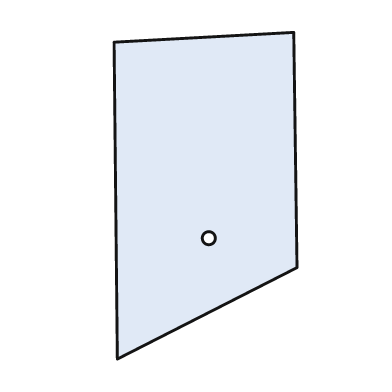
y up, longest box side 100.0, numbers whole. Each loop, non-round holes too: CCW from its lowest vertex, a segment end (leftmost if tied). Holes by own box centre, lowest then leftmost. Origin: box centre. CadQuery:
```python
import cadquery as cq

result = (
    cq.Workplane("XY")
    .moveTo(-27.0, -50.0)
    .lineTo(28.0, -22.0)
    .lineTo(27.0, 50.0)
    .lineTo(-28.0, 47.0)
    .close()
    .moveTo(1.0, -13.0)
    .circle(2.0)
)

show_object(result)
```